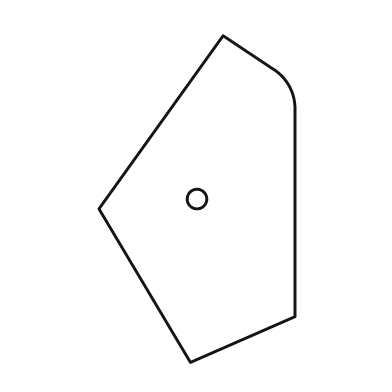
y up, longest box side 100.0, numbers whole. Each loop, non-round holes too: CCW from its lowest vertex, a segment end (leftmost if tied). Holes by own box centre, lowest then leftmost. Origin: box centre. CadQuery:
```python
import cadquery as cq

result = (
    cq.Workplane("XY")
    .moveTo(-2.0, -50.0)
    .lineTo(30.0, -36.0)
    .lineTo(30.0, 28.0)
    .threePointArc((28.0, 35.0), (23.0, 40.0))
    .lineTo(8.0, 50.0)
    .lineTo(-30.0, -3.0)
    .close()
    .moveTo(0.0, 0.0)
    .circle(3.0)
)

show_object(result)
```